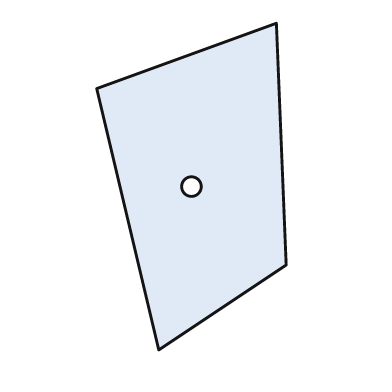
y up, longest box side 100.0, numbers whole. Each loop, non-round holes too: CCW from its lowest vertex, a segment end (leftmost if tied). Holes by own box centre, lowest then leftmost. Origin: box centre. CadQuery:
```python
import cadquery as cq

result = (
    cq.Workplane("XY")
    .moveTo(-10.0, -50.0)
    .lineTo(29.0, -24.0)
    .lineTo(26.0, 50.0)
    .lineTo(-29.0, 30.0)
    .close()
    .moveTo(0.0, 0.0)
    .circle(3.0)
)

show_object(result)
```